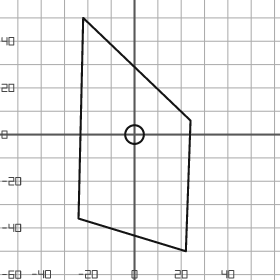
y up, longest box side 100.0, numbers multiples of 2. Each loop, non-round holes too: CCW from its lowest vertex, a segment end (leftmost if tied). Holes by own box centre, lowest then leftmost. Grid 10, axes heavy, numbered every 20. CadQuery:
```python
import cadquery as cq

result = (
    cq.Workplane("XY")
    .moveTo(22.0, -50.0)
    .lineTo(24.0, 6.0)
    .lineTo(-22.0, 50.0)
    .lineTo(-24.0, -36.0)
    .close()
    .moveTo(0.0, 0.0)
    .circle(4.0)
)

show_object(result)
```